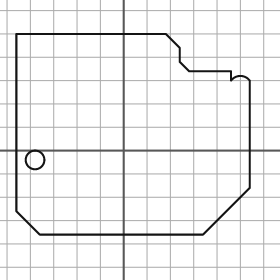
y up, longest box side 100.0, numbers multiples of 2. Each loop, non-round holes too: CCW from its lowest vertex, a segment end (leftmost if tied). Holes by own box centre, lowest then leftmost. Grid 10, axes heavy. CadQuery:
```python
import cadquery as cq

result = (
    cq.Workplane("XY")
    .moveTo(-36.0, -36.0)
    .lineTo(34.0, -36.0)
    .lineTo(54.0, -16.0)
    .lineTo(54.0, 30.0)
    .threePointArc((50.0, 32.0), (46.0, 30.0))
    .lineTo(46.0, 34.0)
    .lineTo(28.0, 34.0)
    .lineTo(24.0, 38.0)
    .lineTo(24.0, 44.0)
    .lineTo(18.0, 50.0)
    .lineTo(-46.0, 50.0)
    .lineTo(-46.0, -26.0)
    .close()
    .moveTo(-38.0, -4.0)
    .circle(4.0)
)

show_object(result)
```